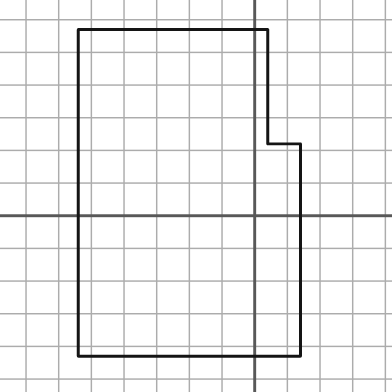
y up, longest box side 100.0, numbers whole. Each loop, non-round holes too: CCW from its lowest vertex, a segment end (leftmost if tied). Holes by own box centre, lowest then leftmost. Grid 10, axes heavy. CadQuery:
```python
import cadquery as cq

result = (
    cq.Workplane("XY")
    .moveTo(-54.0, -43.0)
    .lineTo(14.0, -43.0)
    .lineTo(14.0, 22.0)
    .lineTo(4.0, 22.0)
    .lineTo(4.0, 57.0)
    .lineTo(-54.0, 57.0)
    .close()
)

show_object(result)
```